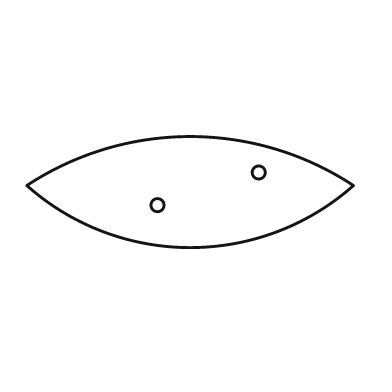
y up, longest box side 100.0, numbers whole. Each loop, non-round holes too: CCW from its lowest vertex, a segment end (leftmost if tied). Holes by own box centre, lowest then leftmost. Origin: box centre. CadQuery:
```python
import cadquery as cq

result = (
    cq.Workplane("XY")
    .moveTo(-50.0, 2.0)
    .threePointArc((0.0, -17.0), (50.0, 2.0))
    .threePointArc((0.0, 17.0), (-50.0, 2.0))
    .close()
    .moveTo(-10.0, -4.0)
    .circle(2.0)
    .moveTo(21.0, 6.0)
    .circle(2.0)
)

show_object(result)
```